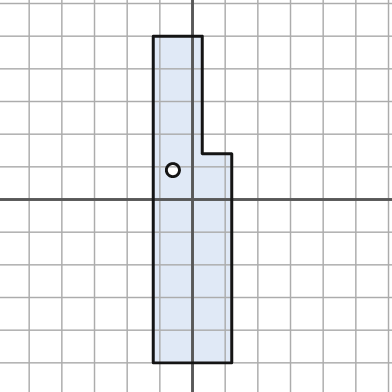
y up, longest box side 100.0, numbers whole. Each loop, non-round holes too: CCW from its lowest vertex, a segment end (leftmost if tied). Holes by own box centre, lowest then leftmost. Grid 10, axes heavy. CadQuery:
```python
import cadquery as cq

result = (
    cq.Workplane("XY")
    .moveTo(-12.0, -50.0)
    .lineTo(12.0, -50.0)
    .lineTo(12.0, 14.0)
    .lineTo(3.0, 14.0)
    .lineTo(3.0, 50.0)
    .lineTo(-12.0, 50.0)
    .close()
    .moveTo(-6.0, 9.0)
    .circle(2.0)
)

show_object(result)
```